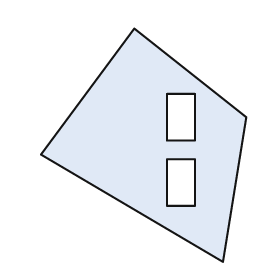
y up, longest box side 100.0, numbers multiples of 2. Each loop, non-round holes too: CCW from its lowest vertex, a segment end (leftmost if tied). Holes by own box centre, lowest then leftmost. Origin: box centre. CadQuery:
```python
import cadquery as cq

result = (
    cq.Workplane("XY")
    .moveTo(34.0, -50.0)
    .lineTo(44.0, 12.0)
    .lineTo(-4.0, 50.0)
    .lineTo(-44.0, -4.0)
    .close()
    .moveTo(10.0, -26.0)
    .lineTo(22.0, -26.0)
    .lineTo(22.0, -6.0)
    .lineTo(10.0, -6.0)
    .close()
    .moveTo(10.0, 2.0)
    .lineTo(22.0, 2.0)
    .lineTo(22.0, 22.0)
    .lineTo(10.0, 22.0)
    .close()
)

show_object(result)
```